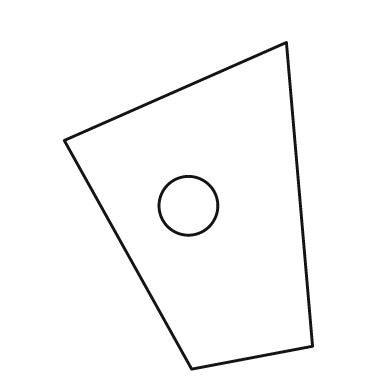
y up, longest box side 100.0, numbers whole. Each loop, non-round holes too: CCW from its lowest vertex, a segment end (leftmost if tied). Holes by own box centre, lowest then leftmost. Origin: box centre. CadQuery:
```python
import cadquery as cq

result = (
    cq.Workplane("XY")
    .moveTo(1.0, -50.0)
    .lineTo(38.0, -43.0)
    .lineTo(30.0, 50.0)
    .lineTo(-38.0, 20.0)
    .close()
    .moveTo(0.0, 0.0)
    .circle(9.0)
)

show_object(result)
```